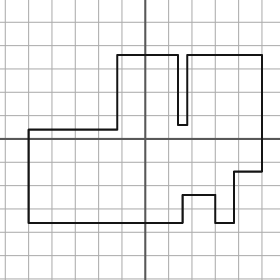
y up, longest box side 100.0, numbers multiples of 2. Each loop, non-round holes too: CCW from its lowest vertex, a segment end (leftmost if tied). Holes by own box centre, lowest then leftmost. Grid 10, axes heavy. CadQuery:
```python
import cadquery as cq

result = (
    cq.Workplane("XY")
    .moveTo(-50.0, -36.0)
    .lineTo(16.0, -36.0)
    .lineTo(16.0, -24.0)
    .lineTo(30.0, -24.0)
    .lineTo(30.0, -36.0)
    .lineTo(38.0, -36.0)
    .lineTo(38.0, -14.0)
    .lineTo(50.0, -14.0)
    .lineTo(50.0, 36.0)
    .lineTo(18.0, 36.0)
    .lineTo(18.0, 6.0)
    .lineTo(14.0, 6.0)
    .lineTo(14.0, 36.0)
    .lineTo(-12.0, 36.0)
    .lineTo(-12.0, 4.0)
    .lineTo(-50.0, 4.0)
    .close()
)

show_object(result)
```